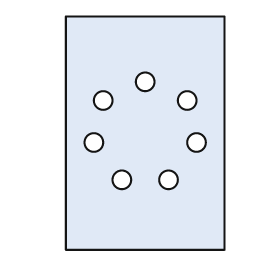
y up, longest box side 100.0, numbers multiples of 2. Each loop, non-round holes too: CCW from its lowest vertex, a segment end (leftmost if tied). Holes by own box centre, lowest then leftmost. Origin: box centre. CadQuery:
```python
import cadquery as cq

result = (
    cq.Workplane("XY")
    .moveTo(-34.0, -50.0)
    .lineTo(34.0, -50.0)
    .lineTo(34.0, 50.0)
    .lineTo(-34.0, 50.0)
    .close()
    .moveTo(-10.0, -20.0)
    .circle(4.0)
    .moveTo(10.0, -20.0)
    .circle(4.0)
    .moveTo(-22.0, -4.0)
    .circle(4.0)
    .moveTo(22.0, -4.0)
    .circle(4.0)
    .moveTo(-18.0, 14.0)
    .circle(4.0)
    .moveTo(18.0, 14.0)
    .circle(4.0)
    .moveTo(0.0, 22.0)
    .circle(4.0)
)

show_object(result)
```